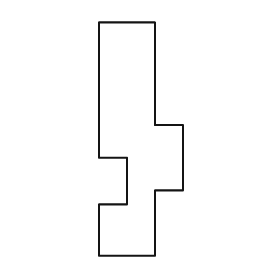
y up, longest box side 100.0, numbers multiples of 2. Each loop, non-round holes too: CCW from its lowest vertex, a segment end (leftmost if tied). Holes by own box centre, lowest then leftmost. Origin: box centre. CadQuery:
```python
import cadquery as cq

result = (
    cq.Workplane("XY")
    .moveTo(-18.0, -50.0)
    .lineTo(6.0, -50.0)
    .lineTo(6.0, -22.0)
    .lineTo(18.0, -22.0)
    .lineTo(18.0, 6.0)
    .lineTo(6.0, 6.0)
    .lineTo(6.0, 50.0)
    .lineTo(-18.0, 50.0)
    .lineTo(-18.0, -8.0)
    .lineTo(-6.0, -8.0)
    .lineTo(-6.0, -28.0)
    .lineTo(-18.0, -28.0)
    .close()
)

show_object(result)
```